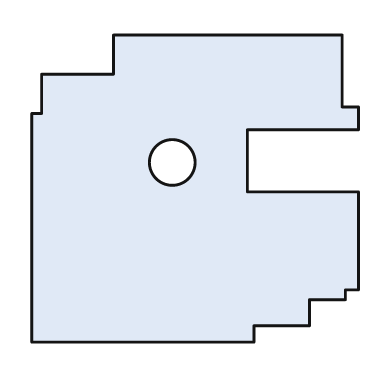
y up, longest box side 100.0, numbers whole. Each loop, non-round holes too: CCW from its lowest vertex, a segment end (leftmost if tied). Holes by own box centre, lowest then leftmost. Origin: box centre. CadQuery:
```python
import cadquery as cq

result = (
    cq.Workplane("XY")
    .moveTo(-50.0, -47.0)
    .lineTo(18.0, -47.0)
    .lineTo(18.0, -42.0)
    .lineTo(35.0, -42.0)
    .lineTo(35.0, -34.0)
    .lineTo(46.0, -34.0)
    .lineTo(46.0, -31.0)
    .lineTo(50.0, -31.0)
    .lineTo(50.0, -1.0)
    .lineTo(16.0, -1.0)
    .lineTo(16.0, 18.0)
    .lineTo(50.0, 18.0)
    .lineTo(50.0, 25.0)
    .lineTo(45.0, 25.0)
    .lineTo(45.0, 47.0)
    .lineTo(-25.0, 47.0)
    .lineTo(-25.0, 35.0)
    .lineTo(-47.0, 35.0)
    .lineTo(-47.0, 23.0)
    .lineTo(-50.0, 23.0)
    .close()
    .moveTo(-7.0, 8.0)
    .circle(7.0)
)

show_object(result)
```